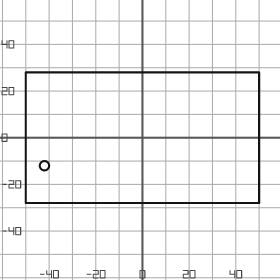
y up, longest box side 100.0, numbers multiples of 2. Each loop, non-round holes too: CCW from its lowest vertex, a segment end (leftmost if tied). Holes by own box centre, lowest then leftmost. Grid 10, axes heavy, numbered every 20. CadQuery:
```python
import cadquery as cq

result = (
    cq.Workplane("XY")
    .moveTo(-50.0, -28.0)
    .lineTo(50.0, -28.0)
    .lineTo(50.0, 28.0)
    .lineTo(-50.0, 28.0)
    .close()
    .moveTo(-42.0, -12.0)
    .circle(2.0)
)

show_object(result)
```